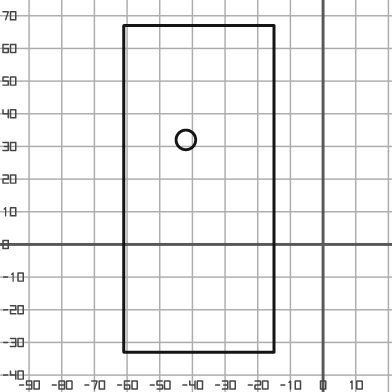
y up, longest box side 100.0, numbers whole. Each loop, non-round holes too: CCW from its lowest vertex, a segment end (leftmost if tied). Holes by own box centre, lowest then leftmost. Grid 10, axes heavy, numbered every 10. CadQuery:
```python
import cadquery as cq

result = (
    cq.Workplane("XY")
    .moveTo(-61.0, -33.0)
    .lineTo(-15.0, -33.0)
    .lineTo(-15.0, 67.0)
    .lineTo(-61.0, 67.0)
    .close()
    .moveTo(-42.0, 32.0)
    .circle(3.0)
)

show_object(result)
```